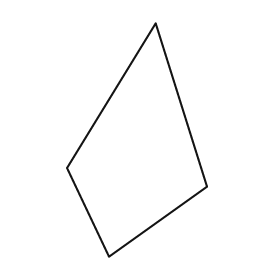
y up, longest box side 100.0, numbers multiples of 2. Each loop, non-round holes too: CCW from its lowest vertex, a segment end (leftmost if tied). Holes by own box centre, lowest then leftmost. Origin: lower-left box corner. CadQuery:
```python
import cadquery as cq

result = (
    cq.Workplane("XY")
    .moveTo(18.0, 0.0)
    .lineTo(60.0, 30.0)
    .lineTo(38.0, 100.0)
    .lineTo(0.0, 38.0)
    .close()
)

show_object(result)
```